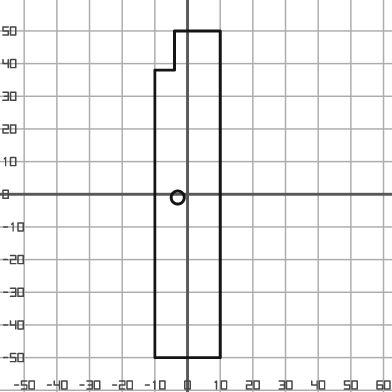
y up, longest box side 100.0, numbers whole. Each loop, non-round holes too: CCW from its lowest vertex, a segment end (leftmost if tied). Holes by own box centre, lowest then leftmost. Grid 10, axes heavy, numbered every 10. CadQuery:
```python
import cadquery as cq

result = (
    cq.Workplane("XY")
    .moveTo(-10.0, -50.0)
    .lineTo(10.0, -50.0)
    .lineTo(10.0, 50.0)
    .lineTo(-4.0, 50.0)
    .lineTo(-4.0, 38.0)
    .lineTo(-10.0, 38.0)
    .close()
    .moveTo(-3.0, -1.0)
    .circle(2.0)
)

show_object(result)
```